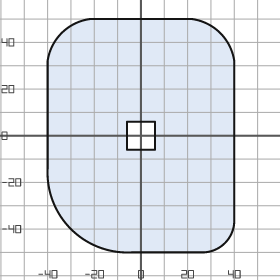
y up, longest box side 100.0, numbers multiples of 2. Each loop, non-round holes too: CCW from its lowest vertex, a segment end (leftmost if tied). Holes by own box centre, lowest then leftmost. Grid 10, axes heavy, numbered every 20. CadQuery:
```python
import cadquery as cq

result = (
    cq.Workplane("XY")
    .moveTo(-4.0, -50.0)
    .lineTo(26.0, -50.0)
    .threePointArc((36.0, -46.0), (40.0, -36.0))
    .lineTo(40.0, 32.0)
    .threePointArc((34.0, 44.0), (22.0, 50.0))
    .lineTo(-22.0, 50.0)
    .threePointArc((-34.0, 44.0), (-40.0, 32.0))
    .lineTo(-40.0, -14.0)
    .threePointArc((-30.0, -40.0), (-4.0, -50.0))
    .close()
    .moveTo(-6.0, -6.0)
    .lineTo(6.0, -6.0)
    .lineTo(6.0, 6.0)
    .lineTo(-6.0, 6.0)
    .close()
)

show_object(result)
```